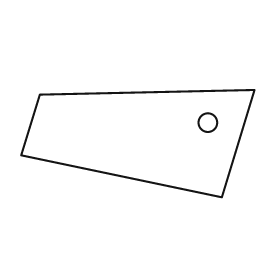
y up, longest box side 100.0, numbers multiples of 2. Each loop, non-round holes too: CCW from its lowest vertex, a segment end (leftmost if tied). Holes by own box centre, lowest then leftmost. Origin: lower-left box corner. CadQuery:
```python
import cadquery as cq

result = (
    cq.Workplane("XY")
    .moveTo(86.0, 0.0)
    .lineTo(100.0, 46.0)
    .lineTo(8.0, 44.0)
    .lineTo(0.0, 18.0)
    .close()
    .moveTo(80.0, 32.0)
    .circle(4.0)
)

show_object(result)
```